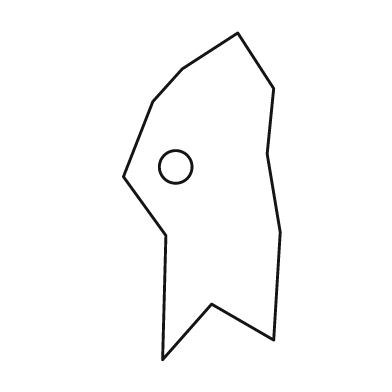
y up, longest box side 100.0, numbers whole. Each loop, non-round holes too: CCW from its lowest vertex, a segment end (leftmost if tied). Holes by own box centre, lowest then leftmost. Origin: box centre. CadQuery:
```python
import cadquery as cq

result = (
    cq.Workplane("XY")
    .moveTo(-12.0, -50.0)
    .lineTo(3.0, -33.0)
    .lineTo(22.0, -44.0)
    .lineTo(24.0, -11.0)
    .lineTo(20.0, 13.0)
    .lineTo(22.0, 33.0)
    .lineTo(11.0, 50.0)
    .lineTo(-6.0, 39.0)
    .lineTo(-15.0, 29.0)
    .lineTo(-24.0, 6.0)
    .lineTo(-11.0, -12.0)
    .close()
    .moveTo(-8.0, 9.0)
    .circle(5.0)
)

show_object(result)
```